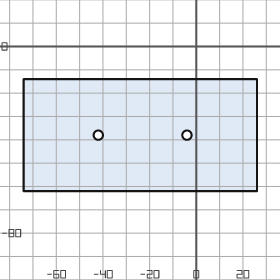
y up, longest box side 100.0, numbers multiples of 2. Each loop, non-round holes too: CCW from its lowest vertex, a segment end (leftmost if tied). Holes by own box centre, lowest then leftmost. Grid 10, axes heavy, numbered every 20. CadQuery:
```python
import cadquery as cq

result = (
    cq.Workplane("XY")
    .moveTo(-74.0, -62.0)
    .lineTo(26.0, -62.0)
    .lineTo(26.0, -14.0)
    .lineTo(-74.0, -14.0)
    .close()
    .moveTo(-42.0, -38.0)
    .circle(2.0)
    .moveTo(-4.0, -38.0)
    .circle(2.0)
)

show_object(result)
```